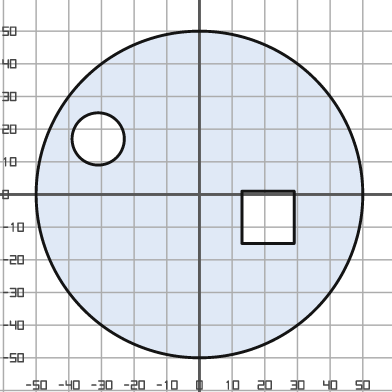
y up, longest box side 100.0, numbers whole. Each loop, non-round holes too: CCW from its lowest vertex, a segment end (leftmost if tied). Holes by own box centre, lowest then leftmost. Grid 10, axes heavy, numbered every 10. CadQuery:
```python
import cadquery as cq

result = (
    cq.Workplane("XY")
    .moveTo(0.0, 0.0)
    .circle(50.0)
    .moveTo(13.0, -15.0)
    .lineTo(29.0, -15.0)
    .lineTo(29.0, 1.0)
    .lineTo(13.0, 1.0)
    .close()
    .moveTo(-31.0, 17.0)
    .circle(8.0)
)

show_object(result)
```